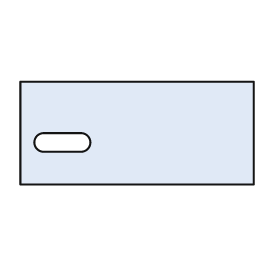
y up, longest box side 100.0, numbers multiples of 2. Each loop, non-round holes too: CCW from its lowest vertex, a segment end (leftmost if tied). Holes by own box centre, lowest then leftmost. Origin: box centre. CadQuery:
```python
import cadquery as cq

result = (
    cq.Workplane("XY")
    .moveTo(-50.0, -22.0)
    .lineTo(50.0, -22.0)
    .lineTo(50.0, 22.0)
    .lineTo(-50.0, 22.0)
    .close()
    .moveTo(-40.0, -8.0)
    .lineTo(-24.0, -8.0)
    .threePointArc((-20.0, -4.0), (-24.0, 0.0))
    .lineTo(-40.0, 0.0)
    .threePointArc((-44.0, -4.0), (-40.0, -8.0))
    .close()
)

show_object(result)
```